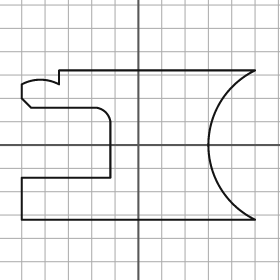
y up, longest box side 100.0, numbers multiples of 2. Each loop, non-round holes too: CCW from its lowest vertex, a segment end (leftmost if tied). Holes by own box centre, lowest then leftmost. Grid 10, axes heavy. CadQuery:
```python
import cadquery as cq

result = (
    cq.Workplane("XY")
    .moveTo(-50.0, -32.0)
    .lineTo(50.0, -32.0)
    .threePointArc((30.0, 0.0), (50.0, 32.0))
    .lineTo(-34.0, 32.0)
    .lineTo(-34.0, 26.0)
    .threePointArc((-42.0, 28.0), (-50.0, 26.0))
    .lineTo(-50.0, 20.0)
    .lineTo(-46.0, 16.0)
    .lineTo(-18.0, 16.0)
    .threePointArc((-14.0, 14.0), (-12.0, 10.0))
    .lineTo(-12.0, -14.0)
    .lineTo(-50.0, -14.0)
    .close()
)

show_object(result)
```